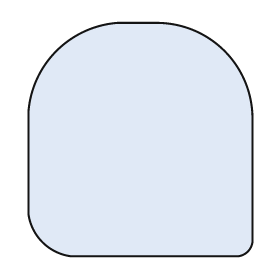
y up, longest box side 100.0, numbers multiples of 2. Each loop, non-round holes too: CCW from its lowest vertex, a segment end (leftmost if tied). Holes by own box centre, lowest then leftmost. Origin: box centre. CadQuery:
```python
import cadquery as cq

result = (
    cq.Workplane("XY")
    .moveTo(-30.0, -50.0)
    .lineTo(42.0, -50.0)
    .threePointArc((46.0, -48.0), (48.0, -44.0))
    .lineTo(48.0, 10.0)
    .threePointArc((36.0, 38.0), (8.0, 50.0))
    .lineTo(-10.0, 50.0)
    .threePointArc((-36.0, 38.0), (-48.0, 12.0))
    .lineTo(-48.0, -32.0)
    .threePointArc((-42.0, -44.0), (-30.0, -50.0))
    .close()
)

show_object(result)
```